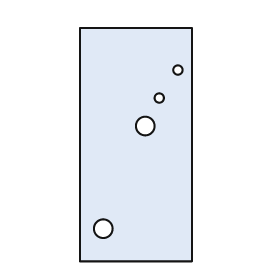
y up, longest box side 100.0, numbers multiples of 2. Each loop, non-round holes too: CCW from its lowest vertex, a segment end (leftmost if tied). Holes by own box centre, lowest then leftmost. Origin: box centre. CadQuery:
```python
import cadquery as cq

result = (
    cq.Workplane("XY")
    .moveTo(-24.0, -50.0)
    .lineTo(24.0, -50.0)
    .lineTo(24.0, 50.0)
    .lineTo(-24.0, 50.0)
    .close()
    .moveTo(-14.0, -36.0)
    .circle(4.0)
    .moveTo(4.0, 8.0)
    .circle(4.0)
    .moveTo(10.0, 20.0)
    .circle(2.0)
    .moveTo(18.0, 32.0)
    .circle(2.0)
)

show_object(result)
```